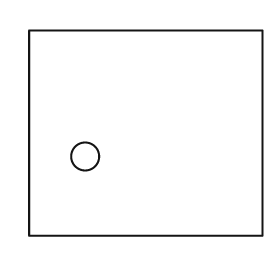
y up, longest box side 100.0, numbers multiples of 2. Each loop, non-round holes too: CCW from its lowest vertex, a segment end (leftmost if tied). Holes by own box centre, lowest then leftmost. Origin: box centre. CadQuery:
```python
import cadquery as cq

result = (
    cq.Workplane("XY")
    .moveTo(-50.0, -44.0)
    .lineTo(50.0, -44.0)
    .lineTo(50.0, 44.0)
    .lineTo(-50.0, 44.0)
    .close()
    .moveTo(-26.0, -10.0)
    .circle(6.0)
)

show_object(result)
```